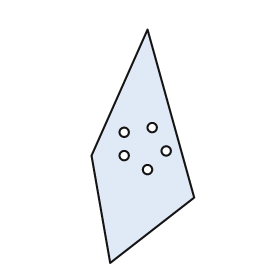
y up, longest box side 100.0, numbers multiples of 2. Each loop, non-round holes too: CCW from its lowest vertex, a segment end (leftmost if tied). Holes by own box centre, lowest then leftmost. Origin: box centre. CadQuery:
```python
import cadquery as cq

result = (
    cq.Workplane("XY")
    .moveTo(-14.0, -50.0)
    .lineTo(22.0, -22.0)
    .lineTo(2.0, 50.0)
    .lineTo(-22.0, -4.0)
    .close()
    .moveTo(2.0, -10.0)
    .circle(2.0)
    .moveTo(-8.0, -4.0)
    .circle(2.0)
    .moveTo(10.0, -2.0)
    .circle(2.0)
    .moveTo(-8.0, 6.0)
    .circle(2.0)
    .moveTo(4.0, 8.0)
    .circle(2.0)
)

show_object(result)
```